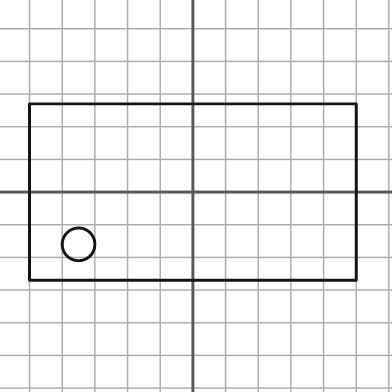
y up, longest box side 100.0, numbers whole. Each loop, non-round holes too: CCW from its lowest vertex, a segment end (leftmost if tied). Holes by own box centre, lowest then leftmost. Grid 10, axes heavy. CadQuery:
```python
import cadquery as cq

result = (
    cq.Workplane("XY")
    .moveTo(-50.0, -27.0)
    .lineTo(50.0, -27.0)
    .lineTo(50.0, 27.0)
    .lineTo(-50.0, 27.0)
    .close()
    .moveTo(-35.0, -16.0)
    .circle(5.0)
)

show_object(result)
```